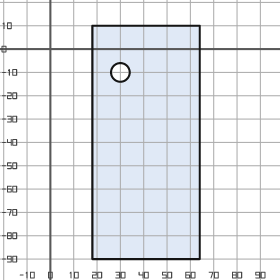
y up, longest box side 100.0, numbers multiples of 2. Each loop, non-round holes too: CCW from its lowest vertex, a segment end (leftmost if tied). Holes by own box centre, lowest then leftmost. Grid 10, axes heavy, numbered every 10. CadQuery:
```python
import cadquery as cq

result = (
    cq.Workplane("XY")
    .moveTo(18.0, -90.0)
    .lineTo(64.0, -90.0)
    .lineTo(64.0, 10.0)
    .lineTo(18.0, 10.0)
    .close()
    .moveTo(30.0, -10.0)
    .circle(4.0)
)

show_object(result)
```